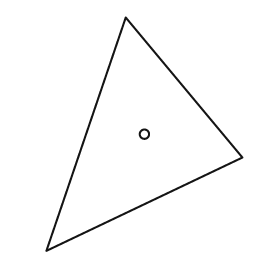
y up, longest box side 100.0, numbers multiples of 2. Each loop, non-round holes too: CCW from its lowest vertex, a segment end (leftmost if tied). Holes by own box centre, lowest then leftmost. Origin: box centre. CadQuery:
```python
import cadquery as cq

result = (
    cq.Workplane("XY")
    .moveTo(-42.0, -50.0)
    .lineTo(42.0, -10.0)
    .lineTo(-8.0, 50.0)
    .close()
    .moveTo(0.0, 0.0)
    .circle(2.0)
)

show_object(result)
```